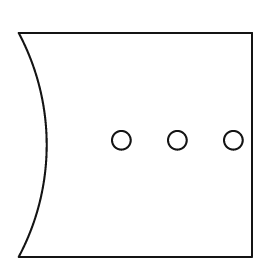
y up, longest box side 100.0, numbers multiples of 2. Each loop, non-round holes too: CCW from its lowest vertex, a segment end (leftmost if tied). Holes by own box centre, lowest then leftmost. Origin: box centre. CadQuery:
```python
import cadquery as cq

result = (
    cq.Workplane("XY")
    .moveTo(-50.0, -48.0)
    .lineTo(50.0, -48.0)
    .lineTo(50.0, 48.0)
    .lineTo(-50.0, 48.0)
    .threePointArc((-38.0, 0.0), (-50.0, -48.0))
    .close()
    .moveTo(-6.0, 2.0)
    .circle(4.0)
    .moveTo(18.0, 2.0)
    .circle(4.0)
    .moveTo(42.0, 2.0)
    .circle(4.0)
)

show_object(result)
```